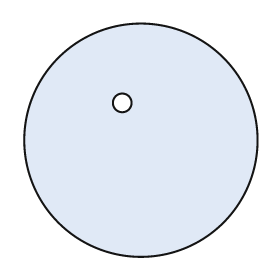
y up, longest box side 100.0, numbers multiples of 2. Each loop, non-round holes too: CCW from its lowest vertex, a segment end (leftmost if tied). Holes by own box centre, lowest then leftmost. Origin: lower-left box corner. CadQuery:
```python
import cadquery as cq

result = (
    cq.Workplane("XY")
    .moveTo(50.0, 50.0)
    .circle(50.0)
    .moveTo(42.0, 66.0)
    .circle(4.0)
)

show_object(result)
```